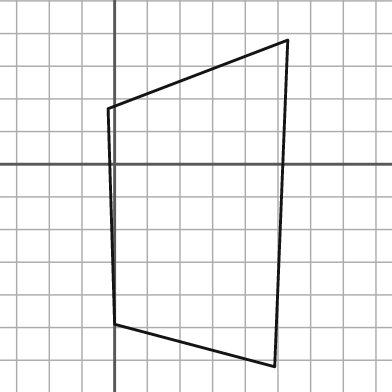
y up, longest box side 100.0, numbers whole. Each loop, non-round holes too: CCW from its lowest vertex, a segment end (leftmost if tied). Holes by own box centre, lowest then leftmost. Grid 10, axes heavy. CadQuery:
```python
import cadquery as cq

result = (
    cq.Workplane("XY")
    .moveTo(49.0, -62.0)
    .lineTo(53.0, 38.0)
    .lineTo(-2.0, 17.0)
    .lineTo(0.0, -49.0)
    .close()
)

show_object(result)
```